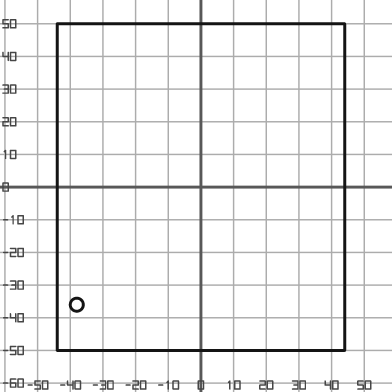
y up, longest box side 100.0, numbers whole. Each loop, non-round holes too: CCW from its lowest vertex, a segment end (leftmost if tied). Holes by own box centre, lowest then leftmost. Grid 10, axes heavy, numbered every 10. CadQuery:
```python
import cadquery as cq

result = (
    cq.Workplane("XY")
    .moveTo(-44.0, -50.0)
    .lineTo(44.0, -50.0)
    .lineTo(44.0, 50.0)
    .lineTo(-44.0, 50.0)
    .close()
    .moveTo(-38.0, -36.0)
    .circle(2.0)
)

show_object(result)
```